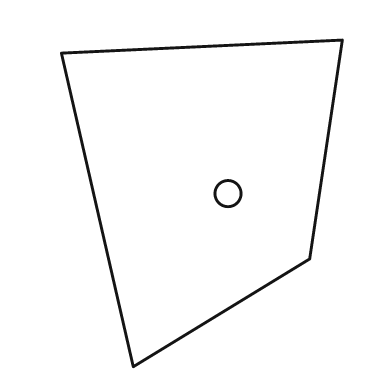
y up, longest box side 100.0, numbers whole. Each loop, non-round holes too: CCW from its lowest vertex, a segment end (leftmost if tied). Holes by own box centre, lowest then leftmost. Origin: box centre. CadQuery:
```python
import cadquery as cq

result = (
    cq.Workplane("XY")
    .moveTo(-21.0, -50.0)
    .lineTo(33.0, -17.0)
    .lineTo(43.0, 50.0)
    .lineTo(-43.0, 46.0)
    .close()
    .moveTo(8.0, 3.0)
    .circle(4.0)
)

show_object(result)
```